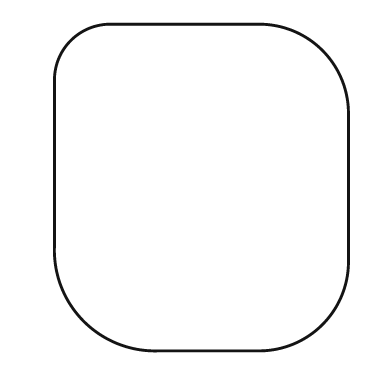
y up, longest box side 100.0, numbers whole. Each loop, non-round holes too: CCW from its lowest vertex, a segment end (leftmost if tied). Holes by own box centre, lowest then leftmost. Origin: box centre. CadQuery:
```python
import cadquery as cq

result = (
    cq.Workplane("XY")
    .moveTo(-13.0, -50.0)
    .lineTo(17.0, -50.0)
    .threePointArc((37.0, -42.0), (45.0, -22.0))
    .lineTo(45.0, 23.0)
    .threePointArc((37.0, 42.0), (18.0, 50.0))
    .lineTo(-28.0, 50.0)
    .threePointArc((-40.0, 45.0), (-45.0, 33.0))
    .lineTo(-45.0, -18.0)
    .threePointArc((-36.0, -41.0), (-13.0, -50.0))
    .close()
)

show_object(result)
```